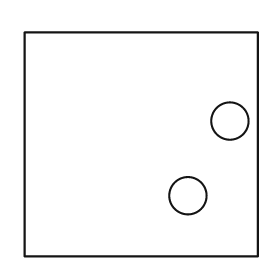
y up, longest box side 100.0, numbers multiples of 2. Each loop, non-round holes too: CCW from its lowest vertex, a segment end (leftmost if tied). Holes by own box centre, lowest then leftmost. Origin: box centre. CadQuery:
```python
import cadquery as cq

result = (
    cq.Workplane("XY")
    .moveTo(-50.0, -48.0)
    .lineTo(50.0, -48.0)
    .lineTo(50.0, 48.0)
    .lineTo(-50.0, 48.0)
    .close()
    .moveTo(20.0, -22.0)
    .circle(8.0)
    .moveTo(38.0, 10.0)
    .circle(8.0)
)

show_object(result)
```